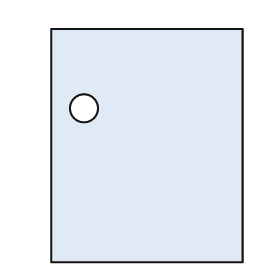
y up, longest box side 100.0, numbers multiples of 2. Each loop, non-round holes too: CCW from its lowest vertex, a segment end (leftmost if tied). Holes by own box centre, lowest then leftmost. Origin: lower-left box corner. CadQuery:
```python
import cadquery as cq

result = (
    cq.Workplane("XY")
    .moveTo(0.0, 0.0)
    .lineTo(82.0, 0.0)
    .lineTo(82.0, 100.0)
    .lineTo(0.0, 100.0)
    .close()
    .moveTo(14.0, 66.0)
    .circle(6.0)
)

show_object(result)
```